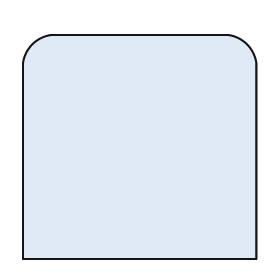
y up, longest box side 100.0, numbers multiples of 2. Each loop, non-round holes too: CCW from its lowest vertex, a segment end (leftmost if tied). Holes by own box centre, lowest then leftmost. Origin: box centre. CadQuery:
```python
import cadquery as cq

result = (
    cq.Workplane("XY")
    .moveTo(-50.0, -48.0)
    .lineTo(50.0, -48.0)
    .lineTo(50.0, 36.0)
    .threePointArc((46.0, 44.0), (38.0, 48.0))
    .lineTo(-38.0, 48.0)
    .threePointArc((-46.0, 44.0), (-50.0, 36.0))
    .close()
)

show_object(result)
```